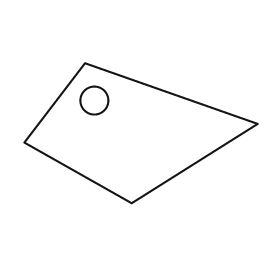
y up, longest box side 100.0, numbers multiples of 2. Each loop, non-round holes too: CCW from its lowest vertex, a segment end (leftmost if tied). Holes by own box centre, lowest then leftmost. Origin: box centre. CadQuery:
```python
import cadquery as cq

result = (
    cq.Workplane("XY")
    .moveTo(-4.0, -30.0)
    .lineTo(50.0, 4.0)
    .lineTo(-24.0, 30.0)
    .lineTo(-50.0, -4.0)
    .close()
    .moveTo(-20.0, 14.0)
    .circle(6.0)
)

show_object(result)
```